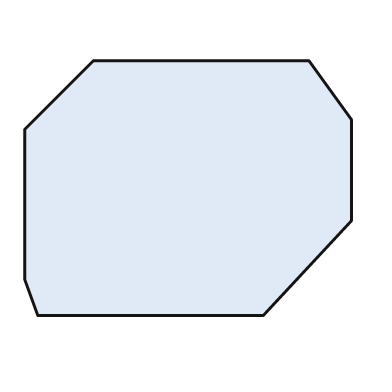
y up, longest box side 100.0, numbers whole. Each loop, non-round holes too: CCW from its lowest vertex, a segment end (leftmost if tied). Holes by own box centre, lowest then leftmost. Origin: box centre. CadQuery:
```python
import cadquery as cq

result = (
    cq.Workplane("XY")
    .moveTo(-46.0, -39.0)
    .lineTo(23.0, -39.0)
    .lineTo(50.0, -10.0)
    .lineTo(50.0, 21.0)
    .lineTo(37.0, 39.0)
    .lineTo(-29.0, 39.0)
    .lineTo(-50.0, 18.0)
    .lineTo(-50.0, -28.0)
    .close()
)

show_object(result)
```